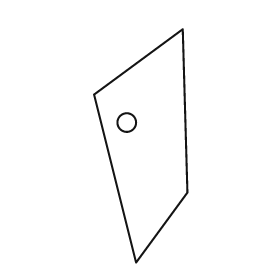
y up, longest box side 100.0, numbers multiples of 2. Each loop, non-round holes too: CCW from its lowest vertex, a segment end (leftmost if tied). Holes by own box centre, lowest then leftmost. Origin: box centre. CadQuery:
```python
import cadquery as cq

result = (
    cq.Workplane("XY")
    .moveTo(-2.0, -50.0)
    .lineTo(20.0, -20.0)
    .lineTo(18.0, 50.0)
    .lineTo(-20.0, 22.0)
    .close()
    .moveTo(-6.0, 10.0)
    .circle(4.0)
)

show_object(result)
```